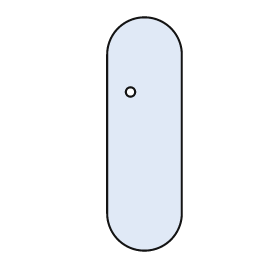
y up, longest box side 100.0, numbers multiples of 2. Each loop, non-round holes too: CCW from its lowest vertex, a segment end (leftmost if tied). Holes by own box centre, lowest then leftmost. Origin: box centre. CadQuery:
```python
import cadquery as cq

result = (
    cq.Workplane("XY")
    .moveTo(-16.0, -34.0)
    .threePointArc((0.0, -50.0), (16.0, -34.0))
    .lineTo(16.0, 34.0)
    .threePointArc((0.0, 50.0), (-16.0, 34.0))
    .close()
    .moveTo(-6.0, 18.0)
    .circle(2.0)
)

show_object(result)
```